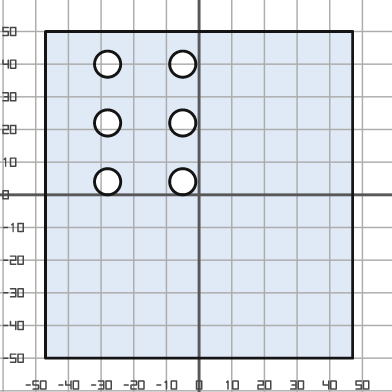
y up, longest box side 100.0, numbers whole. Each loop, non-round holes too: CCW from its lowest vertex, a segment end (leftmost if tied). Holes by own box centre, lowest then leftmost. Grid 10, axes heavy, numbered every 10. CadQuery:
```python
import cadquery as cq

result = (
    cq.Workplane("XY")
    .moveTo(-47.0, -50.0)
    .lineTo(47.0, -50.0)
    .lineTo(47.0, 50.0)
    .lineTo(-47.0, 50.0)
    .close()
    .moveTo(-28.0, 4.0)
    .circle(4.0)
    .moveTo(-5.0, 4.0)
    .circle(4.0)
    .moveTo(-28.0, 22.0)
    .circle(4.0)
    .moveTo(-5.0, 22.0)
    .circle(4.0)
    .moveTo(-28.0, 40.0)
    .circle(4.0)
    .moveTo(-5.0, 40.0)
    .circle(4.0)
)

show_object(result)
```